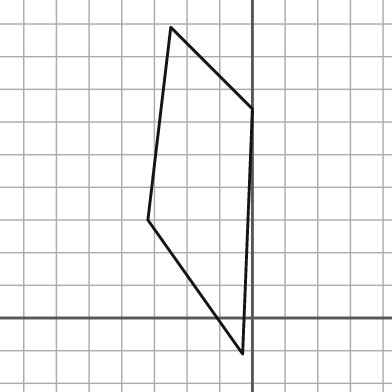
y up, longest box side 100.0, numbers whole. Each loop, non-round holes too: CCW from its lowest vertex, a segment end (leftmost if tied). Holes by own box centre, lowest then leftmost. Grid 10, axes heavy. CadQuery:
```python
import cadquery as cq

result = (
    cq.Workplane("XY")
    .moveTo(-3.0, -11.0)
    .lineTo(0.0, 64.0)
    .lineTo(-25.0, 89.0)
    .lineTo(-32.0, 30.0)
    .close()
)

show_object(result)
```